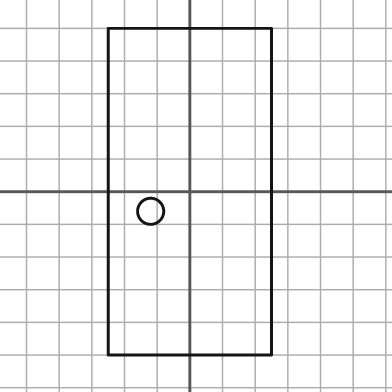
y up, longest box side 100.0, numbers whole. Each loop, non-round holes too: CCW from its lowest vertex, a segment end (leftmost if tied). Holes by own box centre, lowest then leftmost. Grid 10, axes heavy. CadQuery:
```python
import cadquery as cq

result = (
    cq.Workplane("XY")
    .moveTo(-25.0, -50.0)
    .lineTo(25.0, -50.0)
    .lineTo(25.0, 50.0)
    .lineTo(-25.0, 50.0)
    .close()
    .moveTo(-12.0, -6.0)
    .circle(4.0)
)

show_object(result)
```